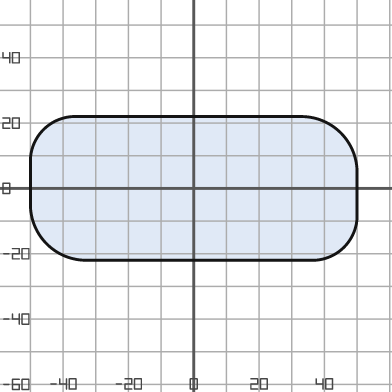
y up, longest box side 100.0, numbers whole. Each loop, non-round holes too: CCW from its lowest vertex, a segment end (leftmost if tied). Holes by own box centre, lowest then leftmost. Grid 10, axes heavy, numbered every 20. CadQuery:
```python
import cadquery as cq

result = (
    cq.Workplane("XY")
    .moveTo(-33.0, -22.0)
    .lineTo(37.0, -22.0)
    .threePointArc((46.0, -18.0), (50.0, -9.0))
    .lineTo(50.0, 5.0)
    .threePointArc((45.0, 17.0), (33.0, 22.0))
    .lineTo(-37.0, 22.0)
    .threePointArc((-46.0, 18.0), (-50.0, 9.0))
    .lineTo(-50.0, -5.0)
    .threePointArc((-45.0, -17.0), (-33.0, -22.0))
    .close()
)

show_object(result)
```